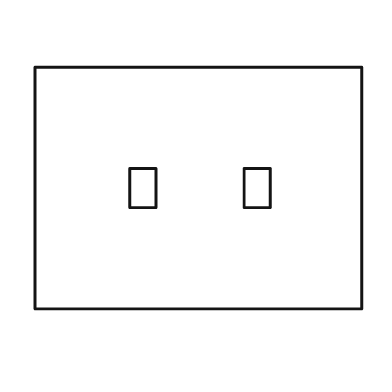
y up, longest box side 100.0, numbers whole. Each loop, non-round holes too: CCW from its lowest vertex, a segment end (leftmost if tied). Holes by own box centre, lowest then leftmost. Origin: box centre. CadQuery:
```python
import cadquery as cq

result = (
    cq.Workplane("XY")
    .moveTo(-50.0, -37.0)
    .lineTo(50.0, -37.0)
    .lineTo(50.0, 37.0)
    .lineTo(-50.0, 37.0)
    .close()
    .moveTo(-21.0, -6.0)
    .lineTo(-13.0, -6.0)
    .lineTo(-13.0, 6.0)
    .lineTo(-21.0, 6.0)
    .close()
    .moveTo(14.0, -6.0)
    .lineTo(22.0, -6.0)
    .lineTo(22.0, 6.0)
    .lineTo(14.0, 6.0)
    .close()
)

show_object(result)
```